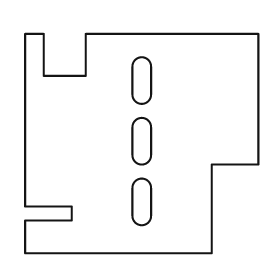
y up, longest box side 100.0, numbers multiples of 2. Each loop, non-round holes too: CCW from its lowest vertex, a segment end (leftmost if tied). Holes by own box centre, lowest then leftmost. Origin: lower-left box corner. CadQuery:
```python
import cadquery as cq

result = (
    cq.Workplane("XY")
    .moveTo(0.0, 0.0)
    .lineTo(80.0, 0.0)
    .lineTo(80.0, 38.0)
    .lineTo(100.0, 38.0)
    .lineTo(100.0, 94.0)
    .lineTo(26.0, 94.0)
    .lineTo(26.0, 76.0)
    .lineTo(8.0, 76.0)
    .lineTo(8.0, 94.0)
    .lineTo(0.0, 94.0)
    .lineTo(0.0, 20.0)
    .lineTo(20.0, 20.0)
    .lineTo(20.0, 14.0)
    .lineTo(0.0, 14.0)
    .close()
    .moveTo(46.0, 16.0)
    .threePointArc((50.0, 12.0), (54.0, 16.0))
    .lineTo(54.0, 28.0)
    .threePointArc((50.0, 32.0), (46.0, 28.0))
    .close()
    .moveTo(46.0, 42.0)
    .threePointArc((50.0, 38.0), (54.0, 42.0))
    .lineTo(54.0, 54.0)
    .threePointArc((50.0, 58.0), (46.0, 54.0))
    .close()
    .moveTo(46.0, 68.0)
    .threePointArc((50.0, 64.0), (54.0, 68.0))
    .lineTo(54.0, 80.0)
    .threePointArc((50.0, 84.0), (46.0, 80.0))
    .close()
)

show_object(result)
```